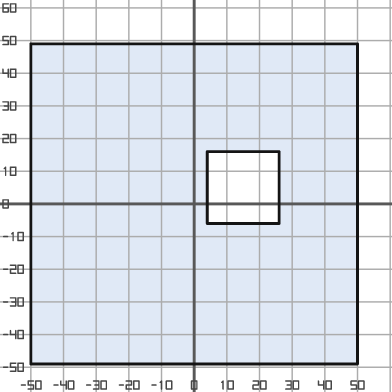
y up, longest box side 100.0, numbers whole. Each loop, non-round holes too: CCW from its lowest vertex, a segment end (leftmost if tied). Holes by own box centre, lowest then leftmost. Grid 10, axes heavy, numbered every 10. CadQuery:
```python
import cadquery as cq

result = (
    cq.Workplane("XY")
    .moveTo(-50.0, -49.0)
    .lineTo(50.0, -49.0)
    .lineTo(50.0, 49.0)
    .lineTo(-50.0, 49.0)
    .close()
    .moveTo(4.0, -6.0)
    .lineTo(26.0, -6.0)
    .lineTo(26.0, 16.0)
    .lineTo(4.0, 16.0)
    .close()
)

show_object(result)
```